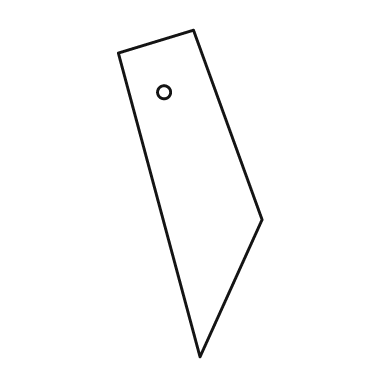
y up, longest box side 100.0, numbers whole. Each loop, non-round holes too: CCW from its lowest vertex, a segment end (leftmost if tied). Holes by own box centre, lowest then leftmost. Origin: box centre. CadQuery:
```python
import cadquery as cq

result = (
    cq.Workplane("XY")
    .moveTo(3.0, -50.0)
    .lineTo(22.0, -8.0)
    .lineTo(1.0, 50.0)
    .lineTo(-22.0, 43.0)
    .close()
    .moveTo(-8.0, 31.0)
    .circle(2.0)
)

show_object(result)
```